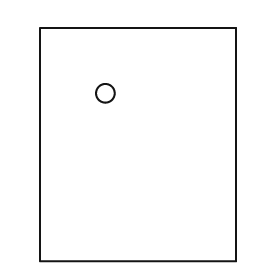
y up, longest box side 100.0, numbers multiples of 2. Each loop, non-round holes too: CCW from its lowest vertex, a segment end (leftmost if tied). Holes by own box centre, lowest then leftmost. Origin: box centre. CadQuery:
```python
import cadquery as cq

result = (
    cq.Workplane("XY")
    .moveTo(-42.0, -50.0)
    .lineTo(42.0, -50.0)
    .lineTo(42.0, 50.0)
    .lineTo(-42.0, 50.0)
    .close()
    .moveTo(-14.0, 22.0)
    .circle(4.0)
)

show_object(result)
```